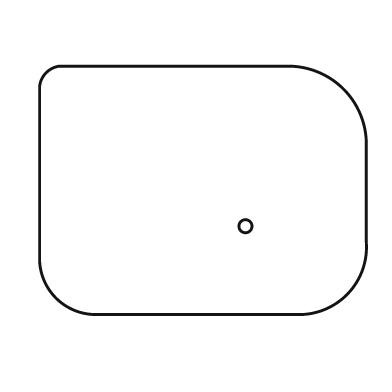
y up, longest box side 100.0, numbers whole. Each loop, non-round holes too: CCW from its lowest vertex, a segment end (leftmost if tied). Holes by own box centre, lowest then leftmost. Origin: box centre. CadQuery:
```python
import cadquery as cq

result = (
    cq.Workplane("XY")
    .moveTo(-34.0, -38.0)
    .lineTo(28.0, -38.0)
    .threePointArc((44.0, -32.0), (50.0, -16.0))
    .lineTo(50.0, 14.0)
    .threePointArc((43.0, 31.0), (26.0, 38.0))
    .lineTo(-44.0, 38.0)
    .threePointArc((-48.0, 36.0), (-50.0, 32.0))
    .lineTo(-50.0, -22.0)
    .threePointArc((-45.0, -33.0), (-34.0, -38.0))
    .close()
    .moveTo(13.0, -11.0)
    .circle(2.0)
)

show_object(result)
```